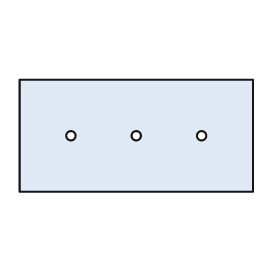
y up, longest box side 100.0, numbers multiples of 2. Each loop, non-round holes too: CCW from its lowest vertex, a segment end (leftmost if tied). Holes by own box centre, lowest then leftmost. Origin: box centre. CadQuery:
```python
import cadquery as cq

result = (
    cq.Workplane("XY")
    .moveTo(-50.0, -24.0)
    .lineTo(50.0, -24.0)
    .lineTo(50.0, 24.0)
    .lineTo(-50.0, 24.0)
    .close()
    .moveTo(-28.0, 0.0)
    .circle(2.0)
    .moveTo(0.0, 0.0)
    .circle(2.0)
    .moveTo(28.0, 0.0)
    .circle(2.0)
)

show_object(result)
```